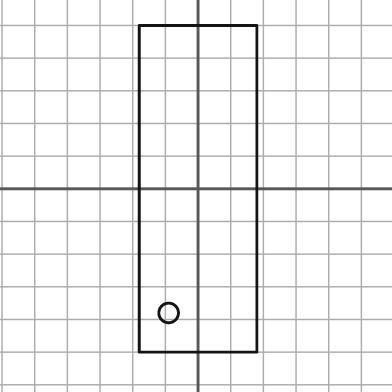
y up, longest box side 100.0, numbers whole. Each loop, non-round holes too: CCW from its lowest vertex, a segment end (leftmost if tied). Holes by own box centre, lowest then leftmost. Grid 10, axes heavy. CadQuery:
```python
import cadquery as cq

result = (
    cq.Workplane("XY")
    .moveTo(-18.0, -50.0)
    .lineTo(18.0, -50.0)
    .lineTo(18.0, 50.0)
    .lineTo(-18.0, 50.0)
    .close()
    .moveTo(-9.0, -38.0)
    .circle(3.0)
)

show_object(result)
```